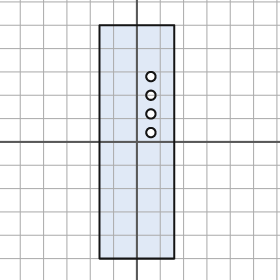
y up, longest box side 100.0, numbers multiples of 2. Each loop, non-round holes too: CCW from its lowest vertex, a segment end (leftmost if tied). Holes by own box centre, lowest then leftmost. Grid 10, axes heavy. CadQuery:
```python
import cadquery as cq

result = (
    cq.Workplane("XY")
    .moveTo(-16.0, -50.0)
    .lineTo(16.0, -50.0)
    .lineTo(16.0, 50.0)
    .lineTo(-16.0, 50.0)
    .close()
    .moveTo(6.0, 4.0)
    .circle(2.0)
    .moveTo(6.0, 12.0)
    .circle(2.0)
    .moveTo(6.0, 20.0)
    .circle(2.0)
    .moveTo(6.0, 28.0)
    .circle(2.0)
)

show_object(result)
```